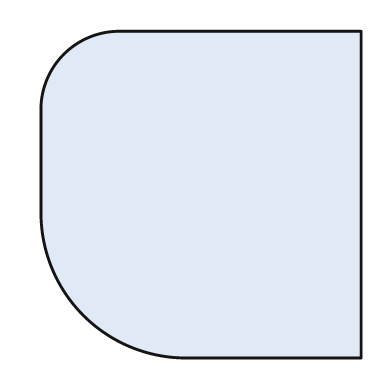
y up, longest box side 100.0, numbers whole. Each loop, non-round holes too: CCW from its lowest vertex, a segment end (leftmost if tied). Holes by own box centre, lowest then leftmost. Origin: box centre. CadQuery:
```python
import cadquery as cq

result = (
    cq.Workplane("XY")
    .moveTo(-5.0, -50.0)
    .lineTo(49.0, -50.0)
    .lineTo(49.0, 50.0)
    .lineTo(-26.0, 50.0)
    .threePointArc((-42.0, 43.0), (-49.0, 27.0))
    .lineTo(-49.0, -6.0)
    .threePointArc((-36.0, -37.0), (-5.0, -50.0))
    .close()
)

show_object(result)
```